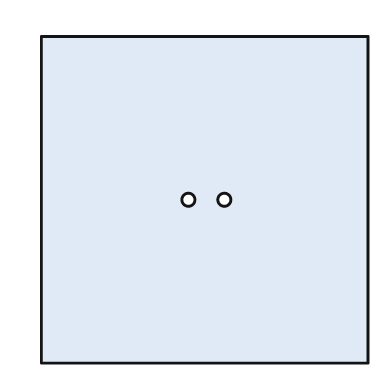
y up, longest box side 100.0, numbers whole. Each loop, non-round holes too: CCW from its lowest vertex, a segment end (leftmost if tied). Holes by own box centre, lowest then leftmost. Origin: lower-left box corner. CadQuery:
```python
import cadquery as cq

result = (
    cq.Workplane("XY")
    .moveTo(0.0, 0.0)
    .lineTo(100.0, 0.0)
    .lineTo(100.0, 100.0)
    .lineTo(0.0, 100.0)
    .close()
    .moveTo(45.0, 50.0)
    .circle(2.0)
    .moveTo(56.0, 50.0)
    .circle(2.0)
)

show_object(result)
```